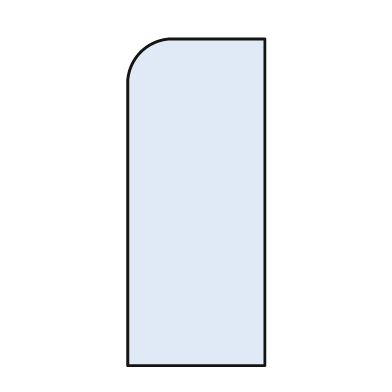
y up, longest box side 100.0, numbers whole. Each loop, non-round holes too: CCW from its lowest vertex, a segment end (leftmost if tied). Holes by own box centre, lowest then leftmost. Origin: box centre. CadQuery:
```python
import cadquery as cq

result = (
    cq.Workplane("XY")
    .moveTo(-21.0, -50.0)
    .lineTo(21.0, -50.0)
    .lineTo(21.0, 50.0)
    .lineTo(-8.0, 50.0)
    .threePointArc((-17.0, 46.0), (-21.0, 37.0))
    .close()
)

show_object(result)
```